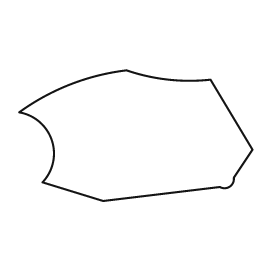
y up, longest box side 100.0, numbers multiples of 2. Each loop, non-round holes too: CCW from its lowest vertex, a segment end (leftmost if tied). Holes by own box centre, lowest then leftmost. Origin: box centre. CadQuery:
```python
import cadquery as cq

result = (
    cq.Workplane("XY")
    .moveTo(-14.0, -28.0)
    .lineTo(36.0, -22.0)
    .threePointArc((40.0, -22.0), (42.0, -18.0))
    .lineTo(50.0, -6.0)
    .lineTo(32.0, 24.0)
    .threePointArc((14.0, 24.0), (-4.0, 28.0))
    .threePointArc((-28.0, 22.0), (-50.0, 10.0))
    .threePointArc((-36.0, -2.0), (-40.0, -20.0))
    .close()
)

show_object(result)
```